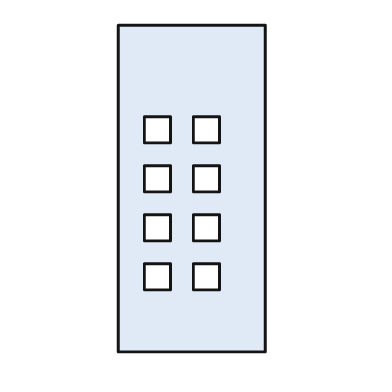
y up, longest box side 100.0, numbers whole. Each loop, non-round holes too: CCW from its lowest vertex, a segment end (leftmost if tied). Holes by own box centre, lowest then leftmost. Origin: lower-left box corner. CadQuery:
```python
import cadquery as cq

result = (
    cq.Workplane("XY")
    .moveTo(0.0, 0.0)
    .lineTo(45.0, 0.0)
    .lineTo(45.0, 100.0)
    .lineTo(0.0, 100.0)
    .close()
    .moveTo(8.0, 19.0)
    .lineTo(16.0, 19.0)
    .lineTo(16.0, 27.0)
    .lineTo(8.0, 27.0)
    .close()
    .moveTo(23.0, 19.0)
    .lineTo(31.0, 19.0)
    .lineTo(31.0, 27.0)
    .lineTo(23.0, 27.0)
    .close()
    .moveTo(8.0, 34.0)
    .lineTo(16.0, 34.0)
    .lineTo(16.0, 42.0)
    .lineTo(8.0, 42.0)
    .close()
    .moveTo(23.0, 34.0)
    .lineTo(31.0, 34.0)
    .lineTo(31.0, 42.0)
    .lineTo(23.0, 42.0)
    .close()
    .moveTo(8.0, 49.0)
    .lineTo(16.0, 49.0)
    .lineTo(16.0, 57.0)
    .lineTo(8.0, 57.0)
    .close()
    .moveTo(23.0, 49.0)
    .lineTo(31.0, 49.0)
    .lineTo(31.0, 57.0)
    .lineTo(23.0, 57.0)
    .close()
    .moveTo(8.0, 64.0)
    .lineTo(16.0, 64.0)
    .lineTo(16.0, 72.0)
    .lineTo(8.0, 72.0)
    .close()
    .moveTo(23.0, 64.0)
    .lineTo(31.0, 64.0)
    .lineTo(31.0, 72.0)
    .lineTo(23.0, 72.0)
    .close()
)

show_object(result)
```